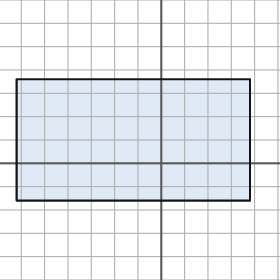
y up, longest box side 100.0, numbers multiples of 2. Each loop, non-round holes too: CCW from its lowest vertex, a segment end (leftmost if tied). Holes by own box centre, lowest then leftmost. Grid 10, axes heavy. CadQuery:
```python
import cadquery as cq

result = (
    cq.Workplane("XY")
    .moveTo(-62.0, -16.0)
    .lineTo(38.0, -16.0)
    .lineTo(38.0, 36.0)
    .lineTo(-62.0, 36.0)
    .close()
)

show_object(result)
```